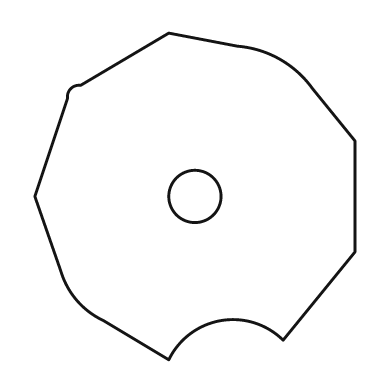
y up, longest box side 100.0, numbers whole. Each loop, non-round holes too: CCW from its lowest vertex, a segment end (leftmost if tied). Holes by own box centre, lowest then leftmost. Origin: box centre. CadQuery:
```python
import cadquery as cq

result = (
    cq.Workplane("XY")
    .moveTo(-8.0, -50.0)
    .threePointArc((8.0, -38.0), (27.0, -44.0))
    .lineTo(49.0, -17.0)
    .lineTo(49.0, 17.0)
    .lineTo(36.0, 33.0)
    .threePointArc((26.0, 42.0), (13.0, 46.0))
    .lineTo(-8.0, 50.0)
    .lineTo(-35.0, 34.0)
    .threePointArc((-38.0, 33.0), (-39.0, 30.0))
    .lineTo(-49.0, 0.0)
    .lineTo(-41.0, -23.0)
    .threePointArc((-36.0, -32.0), (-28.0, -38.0))
    .close()
    .moveTo(0.0, 0.0)
    .circle(8.0)
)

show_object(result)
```